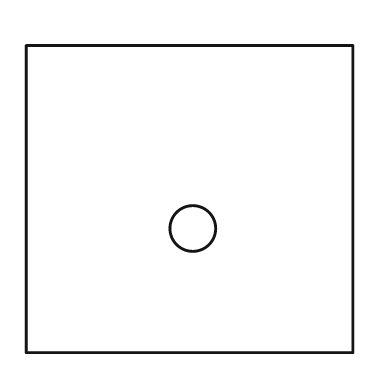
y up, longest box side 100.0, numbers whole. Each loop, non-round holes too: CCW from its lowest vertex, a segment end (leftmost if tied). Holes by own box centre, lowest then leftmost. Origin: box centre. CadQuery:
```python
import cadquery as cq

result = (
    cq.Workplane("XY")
    .moveTo(-50.0, -47.0)
    .lineTo(50.0, -47.0)
    .lineTo(50.0, 47.0)
    .lineTo(-50.0, 47.0)
    .close()
    .moveTo(1.0, -9.0)
    .circle(7.0)
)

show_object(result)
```